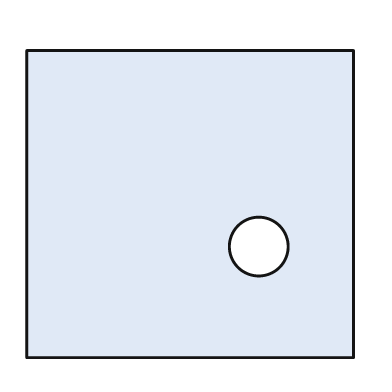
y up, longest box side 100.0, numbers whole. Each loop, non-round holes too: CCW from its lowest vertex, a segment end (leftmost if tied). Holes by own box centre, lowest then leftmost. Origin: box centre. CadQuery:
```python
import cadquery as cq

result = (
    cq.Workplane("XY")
    .moveTo(-50.0, -47.0)
    .lineTo(50.0, -47.0)
    .lineTo(50.0, 47.0)
    .lineTo(-50.0, 47.0)
    .close()
    .moveTo(21.0, -13.0)
    .circle(9.0)
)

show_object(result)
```